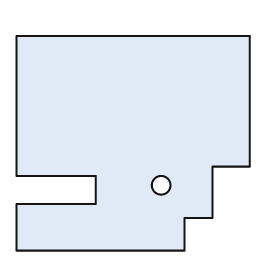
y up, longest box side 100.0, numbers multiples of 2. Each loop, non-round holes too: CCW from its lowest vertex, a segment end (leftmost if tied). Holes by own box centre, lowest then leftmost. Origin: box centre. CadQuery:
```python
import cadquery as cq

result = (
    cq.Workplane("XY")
    .moveTo(-50.0, -46.0)
    .lineTo(22.0, -46.0)
    .lineTo(22.0, -32.0)
    .lineTo(34.0, -32.0)
    .lineTo(34.0, -10.0)
    .lineTo(50.0, -10.0)
    .lineTo(50.0, 46.0)
    .lineTo(-50.0, 46.0)
    .lineTo(-50.0, -14.0)
    .lineTo(-16.0, -14.0)
    .lineTo(-16.0, -26.0)
    .lineTo(-50.0, -26.0)
    .close()
    .moveTo(12.0, -18.0)
    .circle(4.0)
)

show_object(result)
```